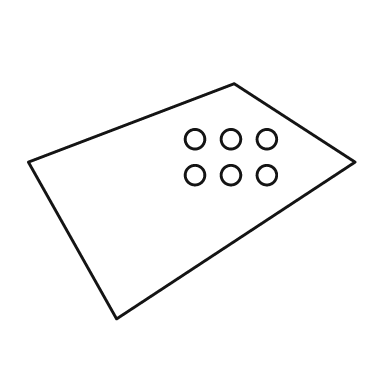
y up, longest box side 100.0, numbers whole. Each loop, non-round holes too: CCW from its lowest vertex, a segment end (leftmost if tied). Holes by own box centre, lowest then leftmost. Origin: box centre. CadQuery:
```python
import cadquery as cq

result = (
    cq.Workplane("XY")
    .moveTo(-23.0, -36.0)
    .lineTo(50.0, 12.0)
    .lineTo(13.0, 36.0)
    .lineTo(-50.0, 12.0)
    .close()
    .moveTo(1.0, 8.0)
    .circle(3.0)
    .moveTo(12.0, 8.0)
    .circle(3.0)
    .moveTo(23.0, 8.0)
    .circle(3.0)
    .moveTo(1.0, 19.0)
    .circle(3.0)
    .moveTo(12.0, 19.0)
    .circle(3.0)
    .moveTo(23.0, 19.0)
    .circle(3.0)
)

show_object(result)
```